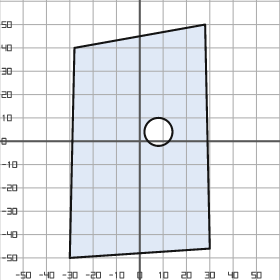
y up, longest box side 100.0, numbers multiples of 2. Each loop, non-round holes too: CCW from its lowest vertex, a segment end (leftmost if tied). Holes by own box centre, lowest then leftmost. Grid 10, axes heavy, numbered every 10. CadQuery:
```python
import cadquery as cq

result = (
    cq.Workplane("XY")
    .moveTo(-30.0, -50.0)
    .lineTo(30.0, -46.0)
    .lineTo(28.0, 50.0)
    .lineTo(-28.0, 40.0)
    .close()
    .moveTo(8.0, 4.0)
    .circle(6.0)
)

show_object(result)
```